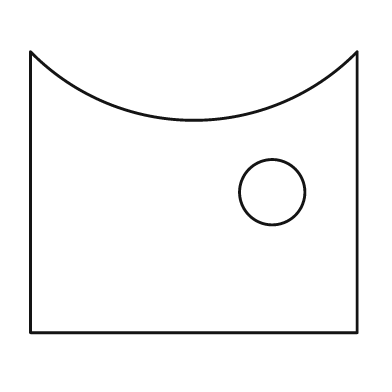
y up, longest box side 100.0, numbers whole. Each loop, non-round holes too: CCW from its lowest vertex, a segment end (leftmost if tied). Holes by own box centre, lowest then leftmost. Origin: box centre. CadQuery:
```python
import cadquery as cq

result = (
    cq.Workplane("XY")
    .moveTo(-50.0, -43.0)
    .lineTo(50.0, -43.0)
    .lineTo(50.0, 43.0)
    .threePointArc((0.0, 22.0), (-50.0, 43.0))
    .close()
    .moveTo(24.0, 0.0)
    .circle(10.0)
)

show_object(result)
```